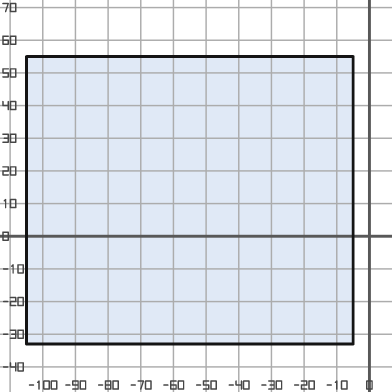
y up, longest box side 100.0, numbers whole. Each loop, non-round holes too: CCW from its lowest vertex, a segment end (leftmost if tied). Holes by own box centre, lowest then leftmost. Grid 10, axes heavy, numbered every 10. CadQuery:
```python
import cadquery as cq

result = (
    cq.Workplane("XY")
    .moveTo(-105.0, -33.0)
    .lineTo(-5.0, -33.0)
    .lineTo(-5.0, 55.0)
    .lineTo(-105.0, 55.0)
    .close()
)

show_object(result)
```